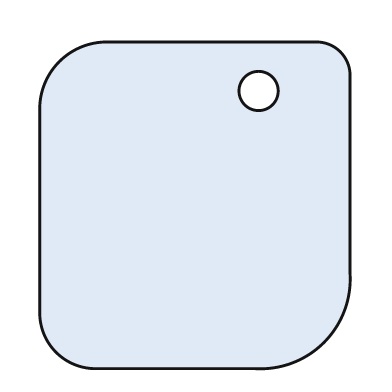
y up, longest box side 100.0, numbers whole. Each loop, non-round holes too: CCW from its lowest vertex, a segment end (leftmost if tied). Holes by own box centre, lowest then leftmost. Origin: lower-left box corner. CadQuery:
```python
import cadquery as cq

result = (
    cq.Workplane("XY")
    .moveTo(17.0, 0.0)
    .lineTo(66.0, 0.0)
    .threePointArc((87.0, 8.0), (95.0, 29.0))
    .lineTo(95.0, 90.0)
    .threePointArc((92.0, 97.0), (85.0, 100.0))
    .lineTo(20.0, 100.0)
    .threePointArc((6.0, 94.0), (0.0, 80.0))
    .lineTo(0.0, 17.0)
    .threePointArc((5.0, 5.0), (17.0, 0.0))
    .close()
    .moveTo(67.0, 85.0)
    .circle(6.0)
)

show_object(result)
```